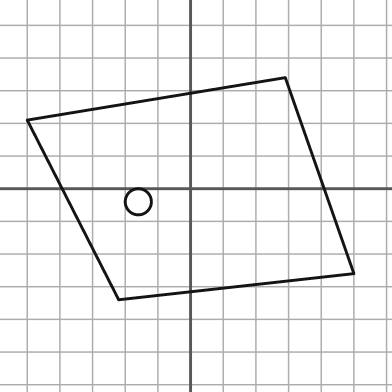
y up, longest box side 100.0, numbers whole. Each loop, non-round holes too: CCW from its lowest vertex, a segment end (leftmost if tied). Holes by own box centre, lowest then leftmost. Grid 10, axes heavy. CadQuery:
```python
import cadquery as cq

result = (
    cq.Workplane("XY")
    .moveTo(-22.0, -34.0)
    .lineTo(50.0, -26.0)
    .lineTo(29.0, 34.0)
    .lineTo(-50.0, 21.0)
    .close()
    .moveTo(-16.0, -4.0)
    .circle(4.0)
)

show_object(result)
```